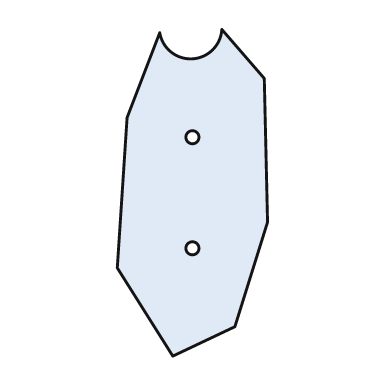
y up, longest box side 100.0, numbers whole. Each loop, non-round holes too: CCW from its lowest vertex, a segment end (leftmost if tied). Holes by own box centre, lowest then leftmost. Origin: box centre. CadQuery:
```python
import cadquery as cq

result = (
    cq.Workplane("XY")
    .moveTo(-6.0, -50.0)
    .lineTo(13.0, -41.0)
    .lineTo(23.0, -9.0)
    .lineTo(22.0, 35.0)
    .lineTo(9.0, 50.0)
    .threePointArc((0.0, 41.0), (-10.0, 49.0))
    .lineTo(-20.0, 23.0)
    .lineTo(-23.0, -23.0)
    .close()
    .moveTo(0.0, -17.0)
    .circle(2.0)
    .moveTo(0.0, 17.0)
    .circle(2.0)
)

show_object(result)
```